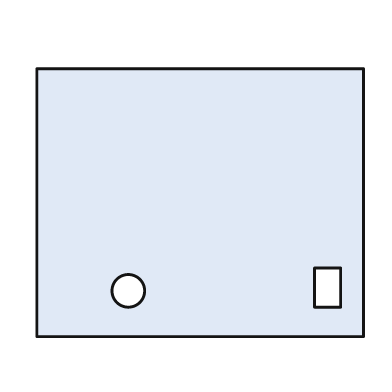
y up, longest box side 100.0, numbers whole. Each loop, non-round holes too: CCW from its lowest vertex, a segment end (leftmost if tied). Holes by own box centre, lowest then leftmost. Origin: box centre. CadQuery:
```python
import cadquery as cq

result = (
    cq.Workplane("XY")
    .moveTo(-50.0, -41.0)
    .lineTo(50.0, -41.0)
    .lineTo(50.0, 41.0)
    .lineTo(-50.0, 41.0)
    .close()
    .moveTo(-22.0, -27.0)
    .circle(5.0)
    .moveTo(35.0, -32.0)
    .lineTo(43.0, -32.0)
    .lineTo(43.0, -20.0)
    .lineTo(35.0, -20.0)
    .close()
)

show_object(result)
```